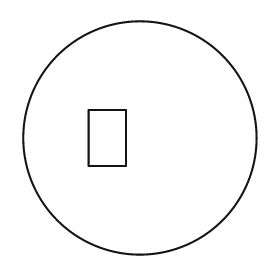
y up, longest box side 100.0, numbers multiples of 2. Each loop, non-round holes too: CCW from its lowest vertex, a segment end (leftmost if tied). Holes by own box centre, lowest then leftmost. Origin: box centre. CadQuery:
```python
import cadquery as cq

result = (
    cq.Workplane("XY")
    .moveTo(0.0, 0.0)
    .circle(50.0)
    .moveTo(-22.0, -12.0)
    .lineTo(-6.0, -12.0)
    .lineTo(-6.0, 12.0)
    .lineTo(-22.0, 12.0)
    .close()
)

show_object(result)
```